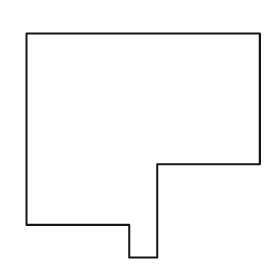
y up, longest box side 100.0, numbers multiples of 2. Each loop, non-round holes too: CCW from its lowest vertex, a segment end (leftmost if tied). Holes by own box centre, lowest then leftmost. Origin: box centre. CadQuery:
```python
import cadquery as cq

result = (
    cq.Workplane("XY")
    .moveTo(-6.0, -48.0)
    .lineTo(6.0, -48.0)
    .lineTo(6.0, -8.0)
    .lineTo(50.0, -8.0)
    .lineTo(50.0, 48.0)
    .lineTo(-50.0, 48.0)
    .lineTo(-50.0, -34.0)
    .lineTo(-6.0, -34.0)
    .close()
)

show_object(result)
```